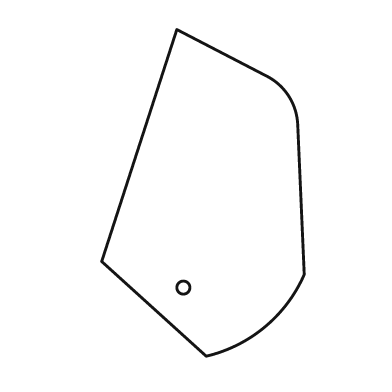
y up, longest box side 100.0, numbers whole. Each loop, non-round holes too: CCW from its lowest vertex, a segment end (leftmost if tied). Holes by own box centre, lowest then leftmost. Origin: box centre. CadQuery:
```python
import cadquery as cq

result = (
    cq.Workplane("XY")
    .moveTo(1.0, -50.0)
    .threePointArc((19.0, -41.0), (31.0, -25.0))
    .lineTo(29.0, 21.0)
    .threePointArc((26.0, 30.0), (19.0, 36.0))
    .lineTo(-8.0, 50.0)
    .lineTo(-31.0, -21.0)
    .close()
    .moveTo(-6.0, -29.0)
    .circle(2.0)
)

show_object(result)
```